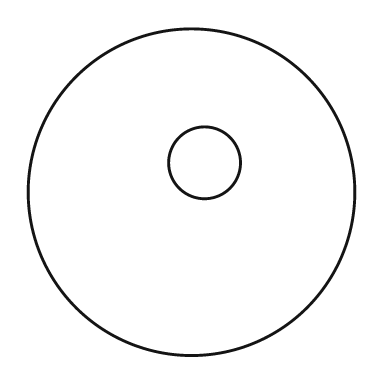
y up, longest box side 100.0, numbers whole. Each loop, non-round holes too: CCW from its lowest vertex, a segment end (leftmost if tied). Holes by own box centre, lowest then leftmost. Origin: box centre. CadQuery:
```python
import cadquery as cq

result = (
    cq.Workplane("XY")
    .moveTo(0.0, 0.0)
    .circle(50.0)
    .moveTo(4.0, 9.0)
    .circle(11.0)
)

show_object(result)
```